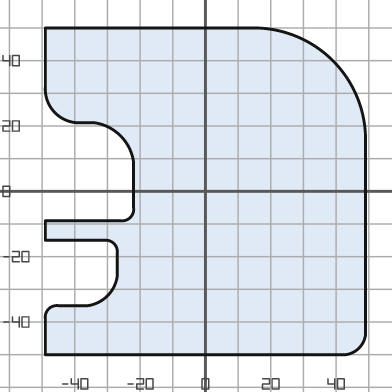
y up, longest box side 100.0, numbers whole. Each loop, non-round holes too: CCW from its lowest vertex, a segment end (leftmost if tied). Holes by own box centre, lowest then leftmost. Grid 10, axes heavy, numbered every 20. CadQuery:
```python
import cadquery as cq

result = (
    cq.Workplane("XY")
    .moveTo(-49.0, -50.0)
    .lineTo(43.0, -50.0)
    .threePointArc((47.0, -48.0), (49.0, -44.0))
    .lineTo(49.0, 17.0)
    .threePointArc((39.0, 40.0), (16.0, 50.0))
    .lineTo(-49.0, 50.0)
    .lineTo(-49.0, 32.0)
    .threePointArc((-46.0, 24.0), (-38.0, 21.0))
    .lineTo(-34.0, 21.0)
    .threePointArc((-26.0, 17.0), (-22.0, 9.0))
    .lineTo(-22.0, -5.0)
    .threePointArc((-23.0, -8.0), (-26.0, -9.0))
    .lineTo(-49.0, -9.0)
    .lineTo(-49.0, -15.0)
    .lineTo(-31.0, -15.0)
    .threePointArc((-28.0, -16.0), (-27.0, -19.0))
    .lineTo(-27.0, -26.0)
    .threePointArc((-30.0, -32.0), (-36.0, -35.0))
    .lineTo(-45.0, -35.0)
    .threePointArc((-48.0, -36.0), (-49.0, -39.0))
    .close()
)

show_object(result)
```